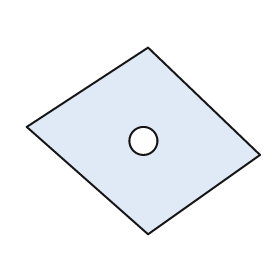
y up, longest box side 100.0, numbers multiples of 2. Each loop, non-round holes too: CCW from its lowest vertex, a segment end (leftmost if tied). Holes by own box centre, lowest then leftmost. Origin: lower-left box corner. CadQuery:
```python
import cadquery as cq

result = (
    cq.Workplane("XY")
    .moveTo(52.0, 0.0)
    .lineTo(100.0, 34.0)
    .lineTo(52.0, 80.0)
    .lineTo(0.0, 46.0)
    .close()
    .moveTo(50.0, 40.0)
    .circle(6.0)
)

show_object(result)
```